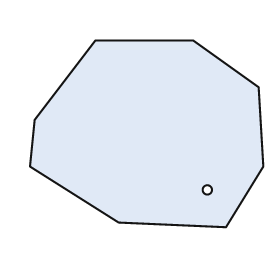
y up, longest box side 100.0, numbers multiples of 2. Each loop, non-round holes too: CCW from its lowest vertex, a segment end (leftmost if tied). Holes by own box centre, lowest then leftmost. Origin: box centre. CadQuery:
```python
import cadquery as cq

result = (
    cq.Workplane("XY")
    .moveTo(34.0, -40.0)
    .lineTo(50.0, -14.0)
    .lineTo(48.0, 20.0)
    .lineTo(20.0, 40.0)
    .lineTo(-22.0, 40.0)
    .lineTo(-48.0, 6.0)
    .lineTo(-50.0, -14.0)
    .lineTo(-12.0, -38.0)
    .close()
    .moveTo(26.0, -24.0)
    .circle(2.0)
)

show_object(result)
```